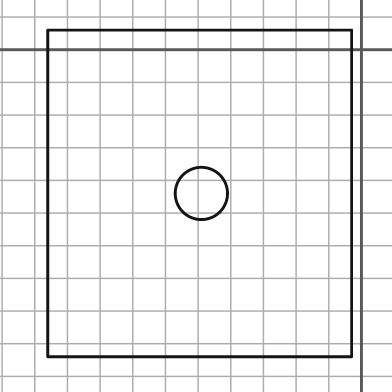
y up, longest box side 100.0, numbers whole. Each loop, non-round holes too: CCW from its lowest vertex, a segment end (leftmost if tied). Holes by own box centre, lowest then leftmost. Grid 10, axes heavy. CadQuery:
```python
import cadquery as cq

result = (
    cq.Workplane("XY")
    .moveTo(-96.0, -94.0)
    .lineTo(-3.0, -94.0)
    .lineTo(-3.0, 6.0)
    .lineTo(-96.0, 6.0)
    .close()
    .moveTo(-49.0, -44.0)
    .circle(8.0)
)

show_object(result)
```